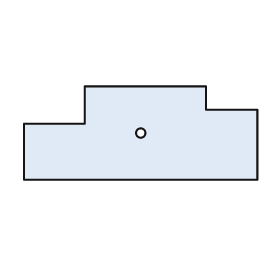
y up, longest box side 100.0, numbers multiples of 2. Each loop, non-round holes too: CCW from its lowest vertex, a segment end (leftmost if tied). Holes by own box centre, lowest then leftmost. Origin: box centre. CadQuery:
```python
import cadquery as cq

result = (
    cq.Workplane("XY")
    .moveTo(-50.0, -20.0)
    .lineTo(50.0, -20.0)
    .lineTo(50.0, 10.0)
    .lineTo(28.0, 10.0)
    .lineTo(28.0, 20.0)
    .lineTo(-24.0, 20.0)
    .lineTo(-24.0, 4.0)
    .lineTo(-50.0, 4.0)
    .close()
    .moveTo(0.0, 0.0)
    .circle(2.0)
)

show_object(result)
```